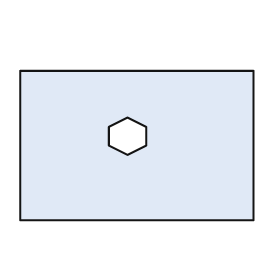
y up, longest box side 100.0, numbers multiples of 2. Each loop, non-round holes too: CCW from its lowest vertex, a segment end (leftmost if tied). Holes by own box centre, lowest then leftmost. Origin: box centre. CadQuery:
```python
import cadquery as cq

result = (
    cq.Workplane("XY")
    .moveTo(-50.0, -32.0)
    .lineTo(50.0, -32.0)
    .lineTo(50.0, 32.0)
    .lineTo(-50.0, 32.0)
    .close()
    .moveTo(-4.0, -4.0)
    .lineTo(4.0, 0.0)
    .lineTo(4.0, 8.0)
    .lineTo(-4.0, 12.0)
    .lineTo(-12.0, 8.0)
    .lineTo(-12.0, 0.0)
    .close()
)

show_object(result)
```